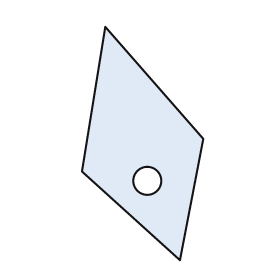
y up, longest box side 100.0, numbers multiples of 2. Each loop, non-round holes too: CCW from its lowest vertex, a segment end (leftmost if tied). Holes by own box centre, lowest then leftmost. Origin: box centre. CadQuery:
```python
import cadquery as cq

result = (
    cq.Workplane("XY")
    .moveTo(16.0, -50.0)
    .lineTo(26.0, 2.0)
    .lineTo(-16.0, 50.0)
    .lineTo(-26.0, -12.0)
    .close()
    .moveTo(2.0, -16.0)
    .circle(6.0)
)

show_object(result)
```